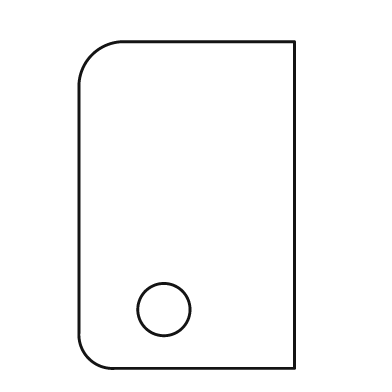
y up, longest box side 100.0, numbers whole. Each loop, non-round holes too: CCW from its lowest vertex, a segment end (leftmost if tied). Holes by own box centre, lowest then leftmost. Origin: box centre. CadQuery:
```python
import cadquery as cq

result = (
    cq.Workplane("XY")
    .moveTo(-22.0, -50.0)
    .lineTo(33.0, -50.0)
    .lineTo(33.0, 50.0)
    .lineTo(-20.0, 50.0)
    .threePointArc((-29.0, 46.0), (-33.0, 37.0))
    .lineTo(-33.0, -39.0)
    .threePointArc((-30.0, -47.0), (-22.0, -50.0))
    .close()
    .moveTo(-7.0, -32.0)
    .circle(8.0)
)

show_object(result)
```